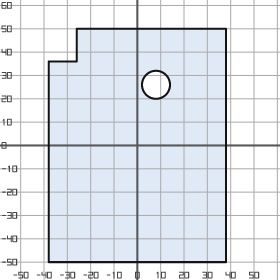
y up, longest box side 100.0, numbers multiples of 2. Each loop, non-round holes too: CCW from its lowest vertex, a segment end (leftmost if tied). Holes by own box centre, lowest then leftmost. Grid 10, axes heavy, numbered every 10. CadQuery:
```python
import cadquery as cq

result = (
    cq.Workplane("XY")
    .moveTo(-38.0, -50.0)
    .lineTo(38.0, -50.0)
    .lineTo(38.0, 50.0)
    .lineTo(-26.0, 50.0)
    .lineTo(-26.0, 36.0)
    .lineTo(-38.0, 36.0)
    .close()
    .moveTo(8.0, 26.0)
    .circle(6.0)
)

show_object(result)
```